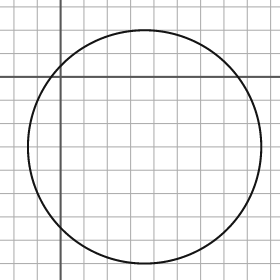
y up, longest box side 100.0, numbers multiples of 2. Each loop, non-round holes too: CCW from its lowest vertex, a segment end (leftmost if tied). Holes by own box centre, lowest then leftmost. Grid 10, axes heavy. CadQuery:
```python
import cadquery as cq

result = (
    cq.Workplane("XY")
    .moveTo(36.0, -30.0)
    .circle(50.0)
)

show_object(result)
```